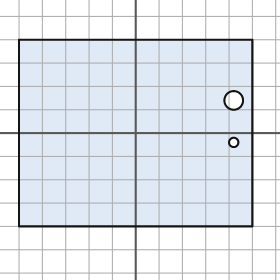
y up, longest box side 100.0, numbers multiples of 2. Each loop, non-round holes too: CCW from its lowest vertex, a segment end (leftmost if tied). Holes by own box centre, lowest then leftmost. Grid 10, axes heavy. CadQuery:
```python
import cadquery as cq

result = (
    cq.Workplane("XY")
    .moveTo(-50.0, -40.0)
    .lineTo(50.0, -40.0)
    .lineTo(50.0, 40.0)
    .lineTo(-50.0, 40.0)
    .close()
    .moveTo(42.0, -4.0)
    .circle(2.0)
    .moveTo(42.0, 14.0)
    .circle(4.0)
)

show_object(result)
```